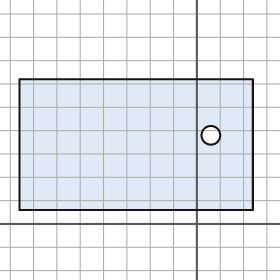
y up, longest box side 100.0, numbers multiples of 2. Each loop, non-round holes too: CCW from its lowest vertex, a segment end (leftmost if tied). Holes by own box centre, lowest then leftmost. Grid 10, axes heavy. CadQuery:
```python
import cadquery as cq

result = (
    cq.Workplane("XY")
    .moveTo(-76.0, 6.0)
    .lineTo(24.0, 6.0)
    .lineTo(24.0, 62.0)
    .lineTo(-76.0, 62.0)
    .close()
    .moveTo(6.0, 38.0)
    .circle(4.0)
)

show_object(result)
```